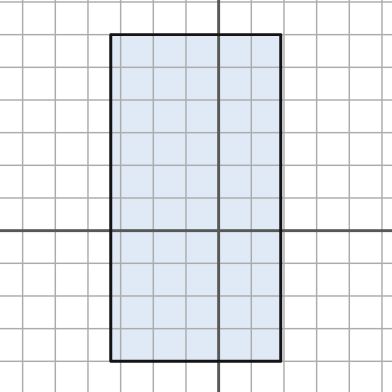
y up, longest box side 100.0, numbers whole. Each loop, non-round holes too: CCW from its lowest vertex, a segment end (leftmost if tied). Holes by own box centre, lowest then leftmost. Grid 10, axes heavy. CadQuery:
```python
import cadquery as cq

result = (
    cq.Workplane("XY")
    .moveTo(-33.0, -40.0)
    .lineTo(19.0, -40.0)
    .lineTo(19.0, 60.0)
    .lineTo(-33.0, 60.0)
    .close()
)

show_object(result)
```